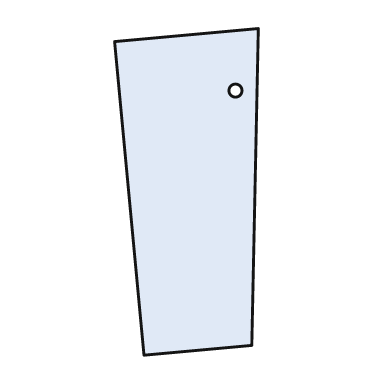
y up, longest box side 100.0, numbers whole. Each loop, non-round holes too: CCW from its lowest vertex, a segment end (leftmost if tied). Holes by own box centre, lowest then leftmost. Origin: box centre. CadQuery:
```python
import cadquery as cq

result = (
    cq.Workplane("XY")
    .moveTo(-13.0, -50.0)
    .lineTo(20.0, -47.0)
    .lineTo(22.0, 50.0)
    .lineTo(-22.0, 46.0)
    .close()
    .moveTo(15.0, 31.0)
    .circle(2.0)
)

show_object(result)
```